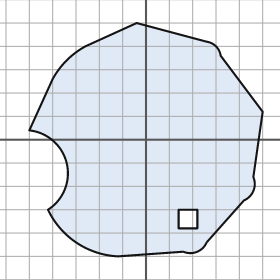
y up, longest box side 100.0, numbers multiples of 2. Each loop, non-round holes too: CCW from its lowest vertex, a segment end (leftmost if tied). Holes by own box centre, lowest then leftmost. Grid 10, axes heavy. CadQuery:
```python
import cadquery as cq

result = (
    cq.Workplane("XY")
    .moveTo(-12.0, -50.0)
    .lineTo(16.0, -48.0)
    .threePointArc((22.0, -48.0), (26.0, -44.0))
    .lineTo(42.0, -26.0)
    .threePointArc((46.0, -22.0), (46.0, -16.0))
    .lineTo(50.0, 12.0)
    .lineTo(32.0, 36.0)
    .threePointArc((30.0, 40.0), (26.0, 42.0))
    .lineTo(-4.0, 50.0)
    .lineTo(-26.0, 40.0)
    .threePointArc((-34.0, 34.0), (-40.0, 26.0))
    .lineTo(-50.0, 4.0)
    .threePointArc((-34.0, -10.0), (-42.0, -30.0))
    .threePointArc((-30.0, -44.0), (-12.0, -50.0))
    .close()
    .moveTo(14.0, -38.0)
    .lineTo(22.0, -38.0)
    .lineTo(22.0, -30.0)
    .lineTo(14.0, -30.0)
    .close()
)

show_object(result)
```